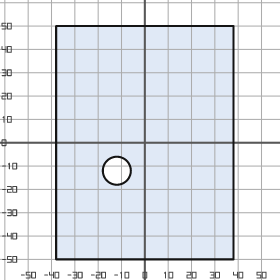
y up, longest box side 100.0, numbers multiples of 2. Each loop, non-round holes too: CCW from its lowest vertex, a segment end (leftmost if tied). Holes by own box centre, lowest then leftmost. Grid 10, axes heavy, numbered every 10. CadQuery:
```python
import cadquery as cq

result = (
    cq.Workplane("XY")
    .moveTo(-38.0, -50.0)
    .lineTo(38.0, -50.0)
    .lineTo(38.0, 50.0)
    .lineTo(-38.0, 50.0)
    .close()
    .moveTo(-12.0, -12.0)
    .circle(6.0)
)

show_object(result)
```